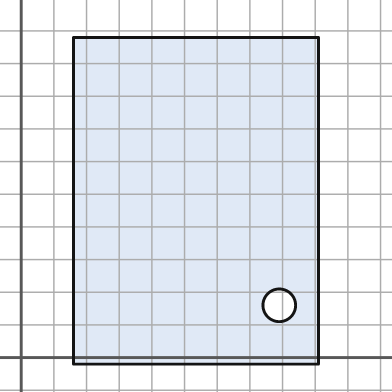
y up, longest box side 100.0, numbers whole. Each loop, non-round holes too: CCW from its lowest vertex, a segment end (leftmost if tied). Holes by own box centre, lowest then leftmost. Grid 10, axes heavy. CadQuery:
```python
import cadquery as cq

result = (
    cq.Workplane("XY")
    .moveTo(16.0, -2.0)
    .lineTo(91.0, -2.0)
    .lineTo(91.0, 98.0)
    .lineTo(16.0, 98.0)
    .close()
    .moveTo(79.0, 16.0)
    .circle(5.0)
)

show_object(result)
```